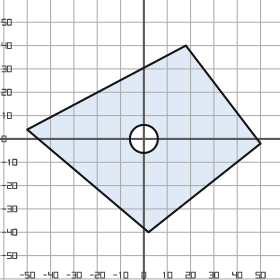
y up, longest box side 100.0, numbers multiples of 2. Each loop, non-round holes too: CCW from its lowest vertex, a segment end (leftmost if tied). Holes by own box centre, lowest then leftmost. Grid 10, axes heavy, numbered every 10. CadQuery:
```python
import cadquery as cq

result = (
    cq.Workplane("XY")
    .moveTo(2.0, -40.0)
    .lineTo(50.0, -2.0)
    .lineTo(18.0, 40.0)
    .lineTo(-50.0, 4.0)
    .close()
    .moveTo(0.0, 0.0)
    .circle(6.0)
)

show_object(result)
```